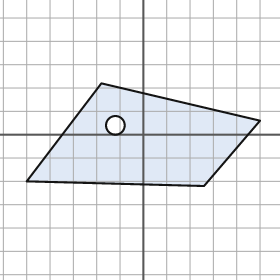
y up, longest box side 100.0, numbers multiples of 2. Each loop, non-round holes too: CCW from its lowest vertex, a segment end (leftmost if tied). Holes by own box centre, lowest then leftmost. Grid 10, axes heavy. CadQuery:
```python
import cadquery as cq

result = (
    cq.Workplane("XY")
    .moveTo(26.0, -22.0)
    .lineTo(50.0, 6.0)
    .lineTo(-18.0, 22.0)
    .lineTo(-50.0, -20.0)
    .close()
    .moveTo(-12.0, 4.0)
    .circle(4.0)
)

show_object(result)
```